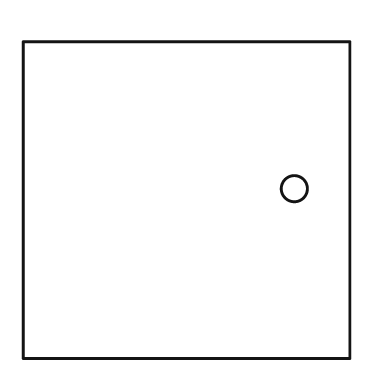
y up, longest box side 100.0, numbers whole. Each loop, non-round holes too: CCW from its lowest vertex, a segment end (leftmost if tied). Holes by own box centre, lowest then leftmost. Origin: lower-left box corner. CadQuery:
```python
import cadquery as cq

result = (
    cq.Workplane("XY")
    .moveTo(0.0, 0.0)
    .lineTo(100.0, 0.0)
    .lineTo(100.0, 97.0)
    .lineTo(0.0, 97.0)
    .close()
    .moveTo(83.0, 52.0)
    .circle(4.0)
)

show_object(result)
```